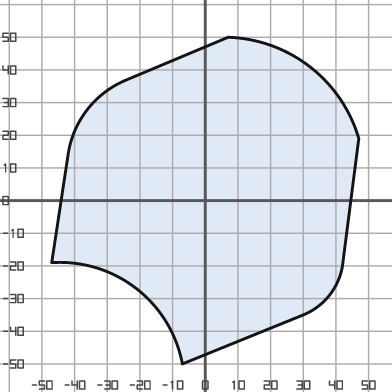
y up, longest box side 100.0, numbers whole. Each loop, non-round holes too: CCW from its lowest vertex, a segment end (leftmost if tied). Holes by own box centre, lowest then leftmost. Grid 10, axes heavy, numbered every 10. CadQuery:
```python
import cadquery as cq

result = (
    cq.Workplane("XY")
    .moveTo(-7.0, -50.0)
    .lineTo(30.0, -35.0)
    .threePointArc((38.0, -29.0), (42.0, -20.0))
    .lineTo(47.0, 19.0)
    .threePointArc((32.0, 41.0), (7.0, 50.0))
    .lineTo(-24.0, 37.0)
    .threePointArc((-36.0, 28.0), (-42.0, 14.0))
    .lineTo(-47.0, -19.0)
    .threePointArc((-21.0, -27.0), (-7.0, -50.0))
    .close()
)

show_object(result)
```